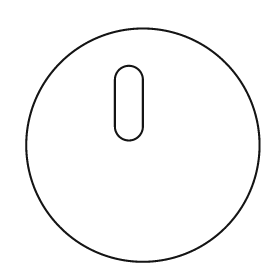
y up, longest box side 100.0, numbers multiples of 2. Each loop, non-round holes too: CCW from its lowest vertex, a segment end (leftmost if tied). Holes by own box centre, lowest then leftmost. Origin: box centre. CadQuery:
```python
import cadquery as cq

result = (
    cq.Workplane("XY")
    .moveTo(0.0, 0.0)
    .circle(50.0)
    .moveTo(-12.0, 8.0)
    .threePointArc((-6.0, 2.0), (0.0, 8.0))
    .lineTo(0.0, 28.0)
    .threePointArc((-6.0, 34.0), (-12.0, 28.0))
    .close()
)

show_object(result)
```